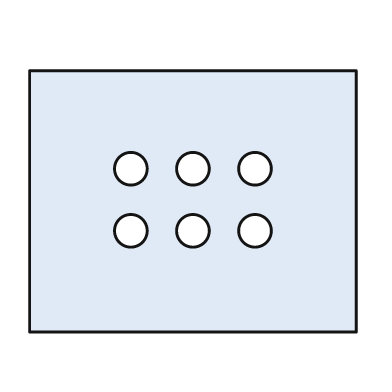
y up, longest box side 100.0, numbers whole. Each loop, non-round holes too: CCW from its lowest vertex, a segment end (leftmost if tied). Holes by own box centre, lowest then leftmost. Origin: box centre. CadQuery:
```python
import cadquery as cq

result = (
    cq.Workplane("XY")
    .moveTo(-50.0, -40.0)
    .lineTo(50.0, -40.0)
    .lineTo(50.0, 40.0)
    .lineTo(-50.0, 40.0)
    .close()
    .moveTo(-19.0, -9.0)
    .circle(5.0)
    .moveTo(0.0, -9.0)
    .circle(5.0)
    .moveTo(19.0, -9.0)
    .circle(5.0)
    .moveTo(-19.0, 10.0)
    .circle(5.0)
    .moveTo(0.0, 10.0)
    .circle(5.0)
    .moveTo(19.0, 10.0)
    .circle(5.0)
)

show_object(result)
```